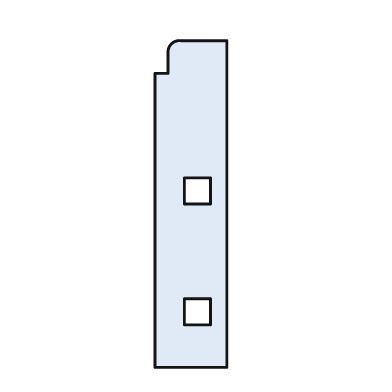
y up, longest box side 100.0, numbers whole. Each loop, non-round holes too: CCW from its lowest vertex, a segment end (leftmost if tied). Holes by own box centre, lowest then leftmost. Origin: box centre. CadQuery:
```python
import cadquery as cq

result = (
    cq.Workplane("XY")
    .moveTo(-11.0, -50.0)
    .lineTo(11.0, -50.0)
    .lineTo(11.0, 50.0)
    .lineTo(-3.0, 50.0)
    .threePointArc((-6.0, 49.0), (-7.0, 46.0))
    .lineTo(-7.0, 40.0)
    .lineTo(-11.0, 40.0)
    .close()
    .moveTo(-2.0, -37.0)
    .lineTo(6.0, -37.0)
    .lineTo(6.0, -29.0)
    .lineTo(-2.0, -29.0)
    .close()
    .moveTo(-2.0, 0.0)
    .lineTo(6.0, 0.0)
    .lineTo(6.0, 8.0)
    .lineTo(-2.0, 8.0)
    .close()
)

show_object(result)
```